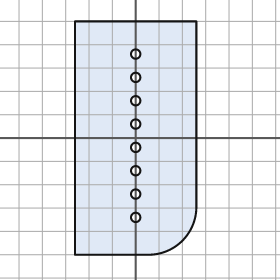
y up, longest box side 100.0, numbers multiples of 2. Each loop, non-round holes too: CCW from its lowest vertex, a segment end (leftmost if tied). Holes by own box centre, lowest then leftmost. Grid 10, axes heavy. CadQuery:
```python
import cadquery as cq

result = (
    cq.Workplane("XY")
    .moveTo(-26.0, -50.0)
    .lineTo(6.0, -50.0)
    .threePointArc((20.0, -44.0), (26.0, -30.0))
    .lineTo(26.0, 50.0)
    .lineTo(-26.0, 50.0)
    .close()
    .moveTo(0.0, -34.0)
    .circle(2.0)
    .moveTo(0.0, -24.0)
    .circle(2.0)
    .moveTo(0.0, -14.0)
    .circle(2.0)
    .moveTo(0.0, -4.0)
    .circle(2.0)
    .moveTo(0.0, 6.0)
    .circle(2.0)
    .moveTo(0.0, 16.0)
    .circle(2.0)
    .moveTo(0.0, 26.0)
    .circle(2.0)
    .moveTo(0.0, 36.0)
    .circle(2.0)
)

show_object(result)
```